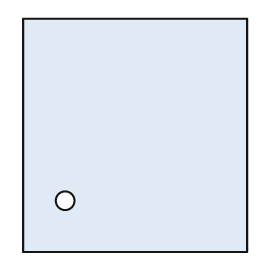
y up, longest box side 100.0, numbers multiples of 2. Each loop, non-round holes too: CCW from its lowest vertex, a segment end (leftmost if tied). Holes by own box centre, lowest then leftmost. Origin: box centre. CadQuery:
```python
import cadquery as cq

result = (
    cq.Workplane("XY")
    .moveTo(-48.0, -50.0)
    .lineTo(48.0, -50.0)
    .lineTo(48.0, 50.0)
    .lineTo(-48.0, 50.0)
    .close()
    .moveTo(-30.0, -28.0)
    .circle(4.0)
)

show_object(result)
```